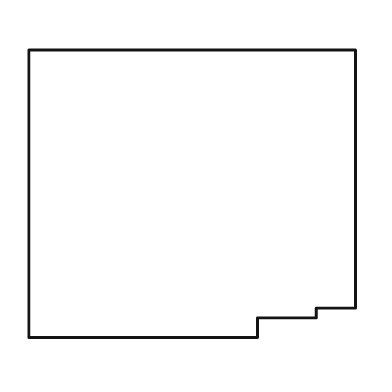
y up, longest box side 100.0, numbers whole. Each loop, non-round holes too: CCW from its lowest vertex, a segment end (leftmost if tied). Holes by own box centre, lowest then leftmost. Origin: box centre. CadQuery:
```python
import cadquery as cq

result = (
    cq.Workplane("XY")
    .moveTo(-50.0, -44.0)
    .lineTo(20.0, -44.0)
    .lineTo(20.0, -38.0)
    .lineTo(38.0, -38.0)
    .lineTo(38.0, -35.0)
    .lineTo(50.0, -35.0)
    .lineTo(50.0, 44.0)
    .lineTo(-50.0, 44.0)
    .close()
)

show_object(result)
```